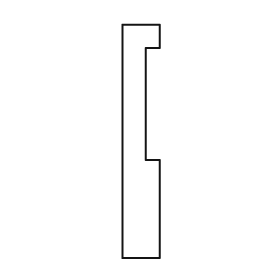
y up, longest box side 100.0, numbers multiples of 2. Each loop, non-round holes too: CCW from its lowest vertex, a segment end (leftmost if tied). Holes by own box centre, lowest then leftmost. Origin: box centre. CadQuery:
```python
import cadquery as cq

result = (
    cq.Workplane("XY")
    .moveTo(-8.0, -50.0)
    .lineTo(8.0, -50.0)
    .lineTo(8.0, -8.0)
    .lineTo(2.0, -8.0)
    .lineTo(2.0, 40.0)
    .lineTo(8.0, 40.0)
    .lineTo(8.0, 50.0)
    .lineTo(-8.0, 50.0)
    .close()
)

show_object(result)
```